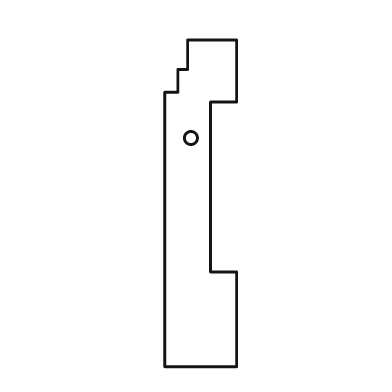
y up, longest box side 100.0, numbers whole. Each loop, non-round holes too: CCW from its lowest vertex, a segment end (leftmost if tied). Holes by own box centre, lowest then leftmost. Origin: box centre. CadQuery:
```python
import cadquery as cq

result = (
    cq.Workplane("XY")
    .moveTo(-11.0, -50.0)
    .lineTo(11.0, -50.0)
    .lineTo(11.0, -21.0)
    .lineTo(3.0, -21.0)
    .lineTo(3.0, 31.0)
    .lineTo(11.0, 31.0)
    .lineTo(11.0, 50.0)
    .lineTo(-4.0, 50.0)
    .lineTo(-4.0, 41.0)
    .lineTo(-7.0, 41.0)
    .lineTo(-7.0, 34.0)
    .lineTo(-11.0, 34.0)
    .close()
    .moveTo(-3.0, 20.0)
    .circle(2.0)
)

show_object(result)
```